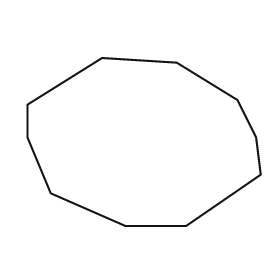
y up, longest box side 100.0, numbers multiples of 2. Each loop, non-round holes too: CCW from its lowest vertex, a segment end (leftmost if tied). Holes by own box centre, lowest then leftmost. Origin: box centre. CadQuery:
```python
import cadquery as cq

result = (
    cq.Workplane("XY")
    .moveTo(-8.0, -36.0)
    .lineTo(18.0, -36.0)
    .lineTo(50.0, -14.0)
    .lineTo(48.0, 2.0)
    .lineTo(40.0, 18.0)
    .lineTo(14.0, 34.0)
    .lineTo(-18.0, 36.0)
    .lineTo(-50.0, 16.0)
    .lineTo(-50.0, 2.0)
    .lineTo(-40.0, -22.0)
    .close()
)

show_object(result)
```